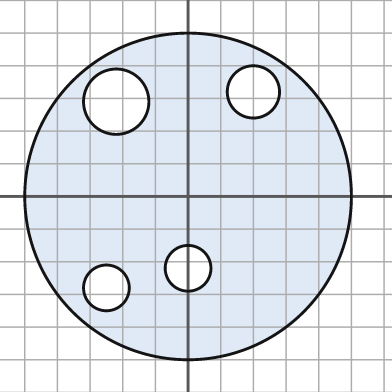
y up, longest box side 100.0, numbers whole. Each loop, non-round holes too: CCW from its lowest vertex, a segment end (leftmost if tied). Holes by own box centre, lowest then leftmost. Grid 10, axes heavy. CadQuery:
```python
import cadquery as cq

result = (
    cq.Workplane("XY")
    .moveTo(0.0, 0.0)
    .circle(50.0)
    .moveTo(-25.0, -28.0)
    .circle(7.0)
    .moveTo(0.0, -22.0)
    .circle(7.0)
    .moveTo(-22.0, 29.0)
    .circle(10.0)
    .moveTo(20.0, 32.0)
    .circle(8.0)
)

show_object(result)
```